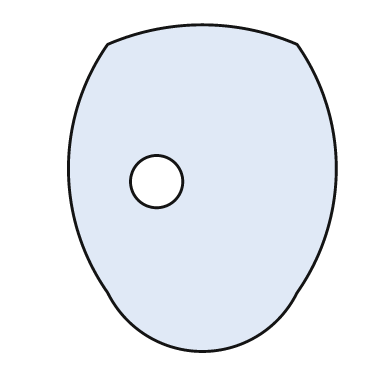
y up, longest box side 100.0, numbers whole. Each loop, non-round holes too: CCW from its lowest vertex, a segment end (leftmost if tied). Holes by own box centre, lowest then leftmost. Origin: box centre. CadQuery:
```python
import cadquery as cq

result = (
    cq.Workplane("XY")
    .moveTo(-29.0, -32.0)
    .threePointArc((0.0, -50.0), (29.0, -32.0))
    .threePointArc((41.0, 6.0), (29.0, 44.0))
    .threePointArc((0.0, 50.0), (-29.0, 44.0))
    .threePointArc((-41.0, 6.0), (-29.0, -32.0))
    .close()
    .moveTo(-14.0, 2.0)
    .circle(8.0)
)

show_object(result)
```